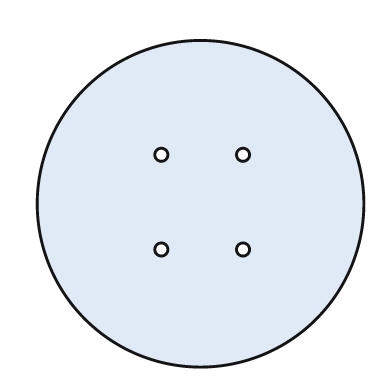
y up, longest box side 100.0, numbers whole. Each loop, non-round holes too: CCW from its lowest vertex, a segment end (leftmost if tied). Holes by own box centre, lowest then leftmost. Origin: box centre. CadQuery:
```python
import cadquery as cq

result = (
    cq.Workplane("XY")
    .moveTo(0.0, 0.0)
    .circle(50.0)
    .moveTo(-12.0, -14.0)
    .circle(2.0)
    .moveTo(13.0, -14.0)
    .circle(2.0)
    .moveTo(-12.0, 15.0)
    .circle(2.0)
    .moveTo(13.0, 15.0)
    .circle(2.0)
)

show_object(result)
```